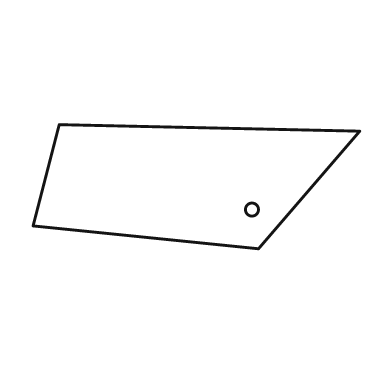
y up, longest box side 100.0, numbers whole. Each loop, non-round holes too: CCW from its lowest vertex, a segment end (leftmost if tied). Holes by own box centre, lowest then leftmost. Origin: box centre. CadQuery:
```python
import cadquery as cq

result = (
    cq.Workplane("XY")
    .moveTo(19.0, -19.0)
    .lineTo(50.0, 17.0)
    .lineTo(-42.0, 19.0)
    .lineTo(-50.0, -12.0)
    .close()
    .moveTo(17.0, -7.0)
    .circle(2.0)
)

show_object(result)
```